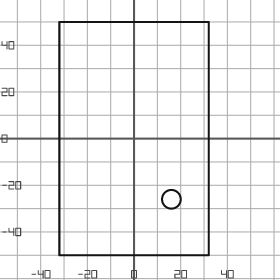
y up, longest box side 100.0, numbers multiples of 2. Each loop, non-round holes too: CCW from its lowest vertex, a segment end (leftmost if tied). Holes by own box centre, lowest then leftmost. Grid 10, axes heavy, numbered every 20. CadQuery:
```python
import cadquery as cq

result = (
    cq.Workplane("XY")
    .moveTo(-32.0, -50.0)
    .lineTo(32.0, -50.0)
    .lineTo(32.0, 50.0)
    .lineTo(-32.0, 50.0)
    .close()
    .moveTo(16.0, -26.0)
    .circle(4.0)
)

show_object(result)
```